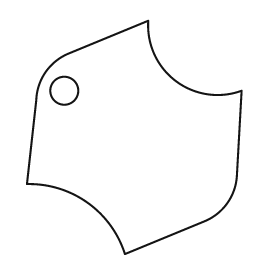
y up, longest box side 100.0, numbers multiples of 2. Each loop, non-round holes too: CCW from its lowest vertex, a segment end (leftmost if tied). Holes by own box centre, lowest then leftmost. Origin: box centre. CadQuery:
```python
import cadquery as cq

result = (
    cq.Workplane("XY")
    .moveTo(-4.0, -50.0)
    .lineTo(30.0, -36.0)
    .threePointArc((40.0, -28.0), (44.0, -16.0))
    .lineTo(46.0, 20.0)
    .threePointArc((18.0, 24.0), (6.0, 50.0))
    .lineTo(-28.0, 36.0)
    .threePointArc((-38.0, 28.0), (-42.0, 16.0))
    .lineTo(-46.0, -20.0)
    .threePointArc((-20.0, -28.0), (-4.0, -50.0))
    .close()
    .moveTo(-30.0, 20.0)
    .circle(6.0)
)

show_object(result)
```